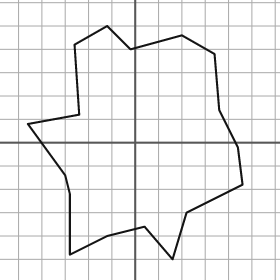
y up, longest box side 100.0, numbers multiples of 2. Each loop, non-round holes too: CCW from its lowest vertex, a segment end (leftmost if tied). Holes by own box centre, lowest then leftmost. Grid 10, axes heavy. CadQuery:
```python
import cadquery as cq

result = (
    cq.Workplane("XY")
    .moveTo(16.0, -50.0)
    .lineTo(22.0, -30.0)
    .lineTo(46.0, -18.0)
    .lineTo(44.0, -2.0)
    .lineTo(36.0, 14.0)
    .lineTo(34.0, 38.0)
    .lineTo(20.0, 46.0)
    .lineTo(-2.0, 40.0)
    .lineTo(-12.0, 50.0)
    .lineTo(-26.0, 42.0)
    .lineTo(-24.0, 12.0)
    .lineTo(-46.0, 8.0)
    .lineTo(-30.0, -14.0)
    .lineTo(-28.0, -22.0)
    .lineTo(-28.0, -48.0)
    .lineTo(-12.0, -40.0)
    .lineTo(4.0, -36.0)
    .close()
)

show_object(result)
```